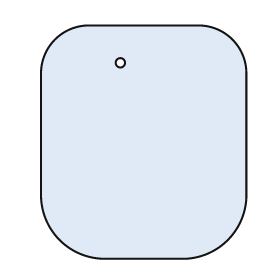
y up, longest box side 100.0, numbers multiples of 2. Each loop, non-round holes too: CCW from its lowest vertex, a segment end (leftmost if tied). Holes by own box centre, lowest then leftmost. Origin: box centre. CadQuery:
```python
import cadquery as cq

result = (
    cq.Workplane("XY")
    .moveTo(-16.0, -50.0)
    .lineTo(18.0, -50.0)
    .threePointArc((36.0, -42.0), (44.0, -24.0))
    .lineTo(44.0, 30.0)
    .threePointArc((38.0, 44.0), (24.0, 50.0))
    .lineTo(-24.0, 50.0)
    .threePointArc((-38.0, 44.0), (-44.0, 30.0))
    .lineTo(-44.0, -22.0)
    .threePointArc((-36.0, -42.0), (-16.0, -50.0))
    .close()
    .moveTo(-10.0, 34.0)
    .circle(2.0)
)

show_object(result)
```